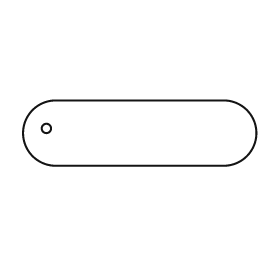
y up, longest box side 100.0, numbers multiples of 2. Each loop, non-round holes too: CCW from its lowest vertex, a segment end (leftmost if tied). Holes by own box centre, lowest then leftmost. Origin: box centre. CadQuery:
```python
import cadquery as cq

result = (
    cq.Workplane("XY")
    .moveTo(-36.0, -14.0)
    .lineTo(36.0, -14.0)
    .threePointArc((50.0, 0.0), (36.0, 14.0))
    .lineTo(-36.0, 14.0)
    .threePointArc((-50.0, 0.0), (-36.0, -14.0))
    .close()
    .moveTo(-40.0, 2.0)
    .circle(2.0)
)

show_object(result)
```